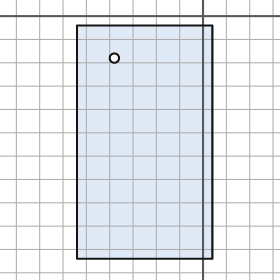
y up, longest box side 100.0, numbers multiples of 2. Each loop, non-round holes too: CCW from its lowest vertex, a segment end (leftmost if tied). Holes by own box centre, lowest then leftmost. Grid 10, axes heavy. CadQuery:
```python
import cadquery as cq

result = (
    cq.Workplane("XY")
    .moveTo(-54.0, -104.0)
    .lineTo(4.0, -104.0)
    .lineTo(4.0, -4.0)
    .lineTo(-54.0, -4.0)
    .close()
    .moveTo(-38.0, -18.0)
    .circle(2.0)
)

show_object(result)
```